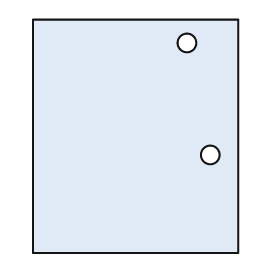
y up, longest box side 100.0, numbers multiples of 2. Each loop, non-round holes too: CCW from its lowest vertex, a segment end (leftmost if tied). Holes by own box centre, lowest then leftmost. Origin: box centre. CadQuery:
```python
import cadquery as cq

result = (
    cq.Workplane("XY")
    .moveTo(-44.0, -50.0)
    .lineTo(44.0, -50.0)
    .lineTo(44.0, 50.0)
    .lineTo(-44.0, 50.0)
    .close()
    .moveTo(32.0, -8.0)
    .circle(4.0)
    .moveTo(22.0, 40.0)
    .circle(4.0)
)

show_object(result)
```